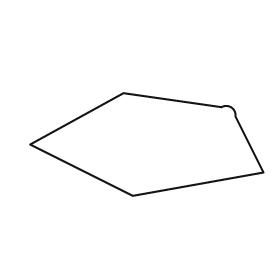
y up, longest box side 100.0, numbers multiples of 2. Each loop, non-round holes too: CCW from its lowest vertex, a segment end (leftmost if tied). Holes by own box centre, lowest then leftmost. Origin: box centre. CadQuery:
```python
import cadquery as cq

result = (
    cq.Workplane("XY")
    .moveTo(-6.0, -22.0)
    .lineTo(50.0, -12.0)
    .lineTo(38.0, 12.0)
    .threePointArc((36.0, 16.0), (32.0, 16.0))
    .lineTo(-10.0, 22.0)
    .lineTo(-50.0, 0.0)
    .close()
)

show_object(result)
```